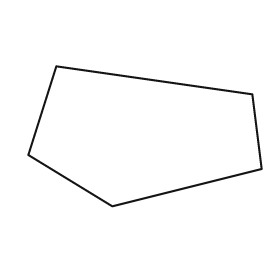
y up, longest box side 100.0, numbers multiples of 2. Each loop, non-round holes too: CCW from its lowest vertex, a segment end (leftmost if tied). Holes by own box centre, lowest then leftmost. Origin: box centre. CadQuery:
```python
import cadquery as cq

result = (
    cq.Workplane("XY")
    .moveTo(-14.0, -30.0)
    .lineTo(50.0, -14.0)
    .lineTo(46.0, 18.0)
    .lineTo(-38.0, 30.0)
    .lineTo(-50.0, -8.0)
    .close()
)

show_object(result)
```